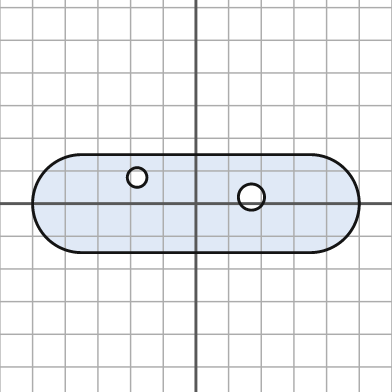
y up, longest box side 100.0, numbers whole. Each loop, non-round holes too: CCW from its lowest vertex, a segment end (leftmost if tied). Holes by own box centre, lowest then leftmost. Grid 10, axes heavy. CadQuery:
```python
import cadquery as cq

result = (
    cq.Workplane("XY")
    .moveTo(-35.0, -15.0)
    .lineTo(35.0, -15.0)
    .threePointArc((50.0, 0.0), (35.0, 15.0))
    .lineTo(-35.0, 15.0)
    .threePointArc((-50.0, 0.0), (-35.0, -15.0))
    .close()
    .moveTo(17.0, 2.0)
    .circle(4.0)
    .moveTo(-18.0, 8.0)
    .circle(3.0)
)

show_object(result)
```